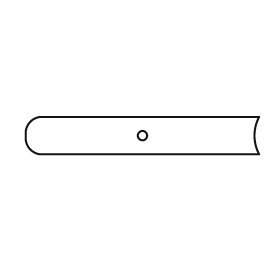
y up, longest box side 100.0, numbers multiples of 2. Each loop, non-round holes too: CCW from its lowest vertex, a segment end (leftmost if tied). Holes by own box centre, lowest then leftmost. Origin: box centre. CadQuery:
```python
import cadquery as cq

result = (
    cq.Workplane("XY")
    .moveTo(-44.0, -8.0)
    .lineTo(50.0, -8.0)
    .threePointArc((48.0, 0.0), (50.0, 8.0))
    .lineTo(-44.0, 8.0)
    .threePointArc((-48.0, 6.0), (-50.0, 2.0))
    .lineTo(-50.0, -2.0)
    .threePointArc((-48.0, -6.0), (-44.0, -8.0))
    .close()
    .moveTo(0.0, 0.0)
    .circle(2.0)
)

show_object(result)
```